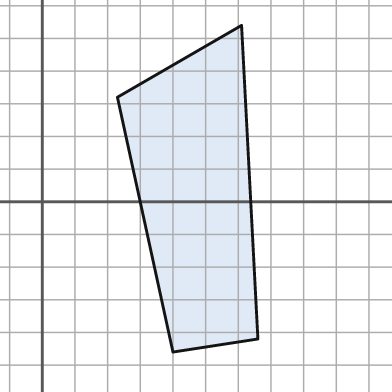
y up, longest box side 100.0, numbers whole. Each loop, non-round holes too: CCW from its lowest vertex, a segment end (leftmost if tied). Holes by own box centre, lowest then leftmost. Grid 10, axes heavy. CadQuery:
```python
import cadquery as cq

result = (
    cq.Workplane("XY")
    .moveTo(40.0, -46.0)
    .lineTo(66.0, -42.0)
    .lineTo(61.0, 54.0)
    .lineTo(23.0, 32.0)
    .close()
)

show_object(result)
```